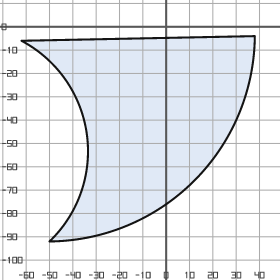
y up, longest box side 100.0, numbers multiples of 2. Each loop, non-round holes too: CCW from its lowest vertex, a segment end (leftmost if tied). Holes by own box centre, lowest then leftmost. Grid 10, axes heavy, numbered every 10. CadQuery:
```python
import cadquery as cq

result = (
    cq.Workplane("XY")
    .moveTo(-50.0, -92.0)
    .threePointArc((12.0, -66.0), (38.0, -4.0))
    .lineTo(-62.0, -6.0)
    .threePointArc((-34.0, -46.0), (-50.0, -92.0))
    .close()
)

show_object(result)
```